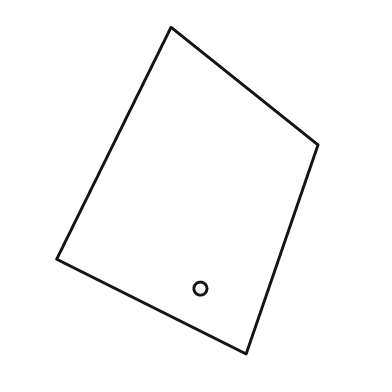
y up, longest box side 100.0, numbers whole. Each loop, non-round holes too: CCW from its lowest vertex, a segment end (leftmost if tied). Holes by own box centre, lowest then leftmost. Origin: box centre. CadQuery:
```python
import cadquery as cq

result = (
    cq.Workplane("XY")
    .moveTo(18.0, -50.0)
    .lineTo(40.0, 14.0)
    .lineTo(-5.0, 50.0)
    .lineTo(-40.0, -21.0)
    .close()
    .moveTo(4.0, -30.0)
    .circle(2.0)
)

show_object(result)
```